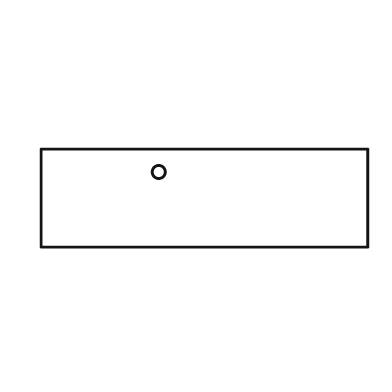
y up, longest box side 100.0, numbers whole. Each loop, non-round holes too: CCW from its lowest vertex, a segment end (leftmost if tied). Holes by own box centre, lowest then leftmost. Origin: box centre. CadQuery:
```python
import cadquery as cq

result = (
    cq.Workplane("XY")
    .moveTo(-50.0, -15.0)
    .lineTo(50.0, -15.0)
    .lineTo(50.0, 15.0)
    .lineTo(-50.0, 15.0)
    .close()
    .moveTo(-14.0, 8.0)
    .circle(2.0)
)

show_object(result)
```